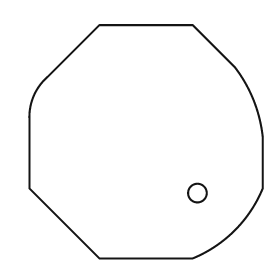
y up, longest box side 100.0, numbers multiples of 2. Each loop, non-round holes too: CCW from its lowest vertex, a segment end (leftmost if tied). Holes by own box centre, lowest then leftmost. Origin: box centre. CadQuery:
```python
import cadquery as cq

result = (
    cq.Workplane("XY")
    .moveTo(-20.0, -50.0)
    .lineTo(20.0, -50.0)
    .threePointArc((38.0, -38.0), (50.0, -20.0))
    .lineTo(50.0, 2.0)
    .threePointArc((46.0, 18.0), (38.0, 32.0))
    .lineTo(20.0, 50.0)
    .lineTo(-20.0, 50.0)
    .lineTo(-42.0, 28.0)
    .threePointArc((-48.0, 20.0), (-50.0, 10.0))
    .lineTo(-50.0, -20.0)
    .close()
    .moveTo(22.0, -22.0)
    .circle(4.0)
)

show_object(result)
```